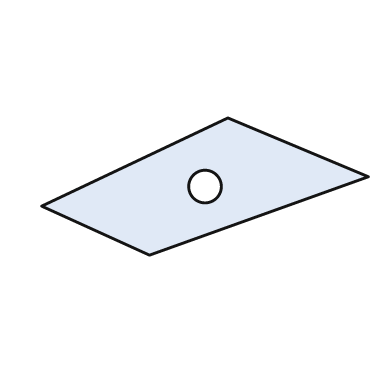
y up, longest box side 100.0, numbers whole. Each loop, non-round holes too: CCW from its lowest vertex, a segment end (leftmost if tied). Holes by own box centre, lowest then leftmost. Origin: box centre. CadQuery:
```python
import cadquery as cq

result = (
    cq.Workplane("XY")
    .moveTo(-17.0, -21.0)
    .lineTo(50.0, 3.0)
    .lineTo(7.0, 21.0)
    .lineTo(-50.0, -6.0)
    .close()
    .moveTo(0.0, 0.0)
    .circle(5.0)
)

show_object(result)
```